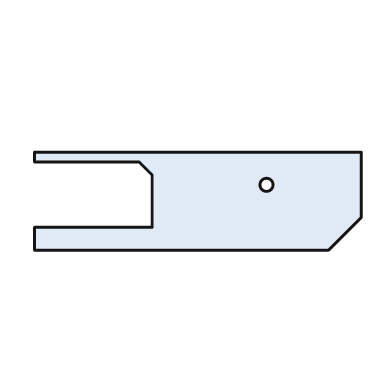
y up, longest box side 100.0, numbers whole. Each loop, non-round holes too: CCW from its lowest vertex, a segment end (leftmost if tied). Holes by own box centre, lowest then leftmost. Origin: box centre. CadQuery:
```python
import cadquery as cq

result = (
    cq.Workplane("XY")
    .moveTo(-50.0, -15.0)
    .lineTo(40.0, -15.0)
    .lineTo(50.0, -5.0)
    .lineTo(50.0, 15.0)
    .lineTo(-50.0, 15.0)
    .lineTo(-50.0, 12.0)
    .lineTo(-18.0, 12.0)
    .lineTo(-14.0, 8.0)
    .lineTo(-14.0, -8.0)
    .lineTo(-50.0, -8.0)
    .close()
    .moveTo(21.0, 5.0)
    .circle(2.0)
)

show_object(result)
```